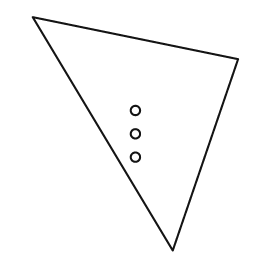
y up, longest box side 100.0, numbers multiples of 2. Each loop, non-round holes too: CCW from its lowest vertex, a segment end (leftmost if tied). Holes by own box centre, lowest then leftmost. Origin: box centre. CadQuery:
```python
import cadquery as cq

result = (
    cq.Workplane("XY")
    .moveTo(16.0, -50.0)
    .lineTo(44.0, 32.0)
    .lineTo(-44.0, 50.0)
    .close()
    .moveTo(0.0, -10.0)
    .circle(2.0)
    .moveTo(0.0, 0.0)
    .circle(2.0)
    .moveTo(0.0, 10.0)
    .circle(2.0)
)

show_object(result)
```